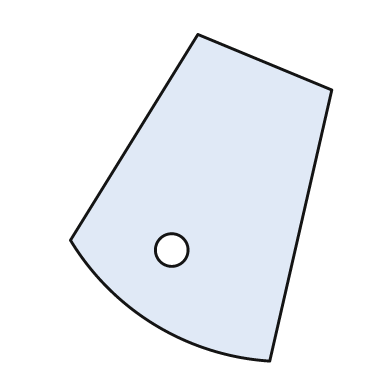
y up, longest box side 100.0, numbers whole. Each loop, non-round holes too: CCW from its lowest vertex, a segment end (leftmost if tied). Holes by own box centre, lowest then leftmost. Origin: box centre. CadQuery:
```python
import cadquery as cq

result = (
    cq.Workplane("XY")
    .moveTo(21.0, -50.0)
    .lineTo(40.0, 33.0)
    .lineTo(-1.0, 50.0)
    .lineTo(-40.0, -13.0)
    .threePointArc((-14.0, -39.0), (21.0, -50.0))
    .close()
    .moveTo(-9.0, -16.0)
    .circle(5.0)
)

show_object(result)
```